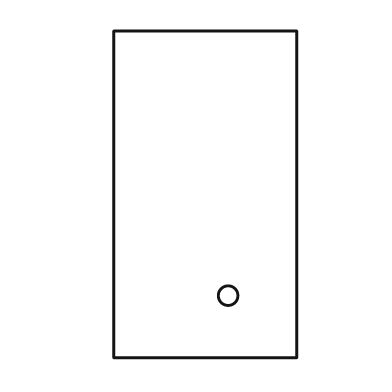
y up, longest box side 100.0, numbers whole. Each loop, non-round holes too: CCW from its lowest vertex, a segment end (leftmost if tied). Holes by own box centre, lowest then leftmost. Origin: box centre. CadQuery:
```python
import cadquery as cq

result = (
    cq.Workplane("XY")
    .moveTo(-28.0, -50.0)
    .lineTo(28.0, -50.0)
    .lineTo(28.0, 50.0)
    .lineTo(-28.0, 50.0)
    .close()
    .moveTo(7.0, -31.0)
    .circle(3.0)
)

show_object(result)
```